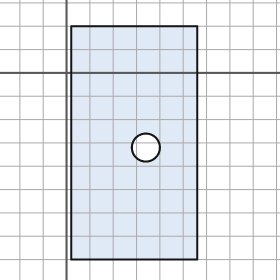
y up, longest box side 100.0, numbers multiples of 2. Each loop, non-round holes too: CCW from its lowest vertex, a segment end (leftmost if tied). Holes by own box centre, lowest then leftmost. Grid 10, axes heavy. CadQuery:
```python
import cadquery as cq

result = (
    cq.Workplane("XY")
    .moveTo(2.0, -80.0)
    .lineTo(56.0, -80.0)
    .lineTo(56.0, 20.0)
    .lineTo(2.0, 20.0)
    .close()
    .moveTo(34.0, -32.0)
    .circle(6.0)
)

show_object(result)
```